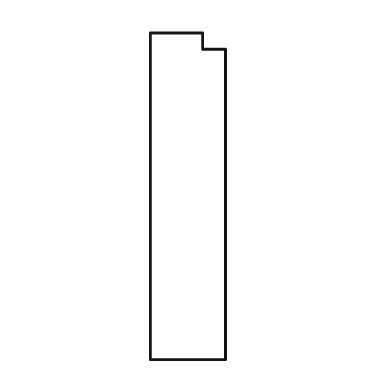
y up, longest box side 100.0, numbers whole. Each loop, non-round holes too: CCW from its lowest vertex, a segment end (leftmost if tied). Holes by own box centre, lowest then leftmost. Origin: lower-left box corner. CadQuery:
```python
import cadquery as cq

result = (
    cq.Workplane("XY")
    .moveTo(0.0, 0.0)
    .lineTo(23.0, 0.0)
    .lineTo(23.0, 95.0)
    .lineTo(16.0, 95.0)
    .lineTo(16.0, 100.0)
    .lineTo(0.0, 100.0)
    .close()
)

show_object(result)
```